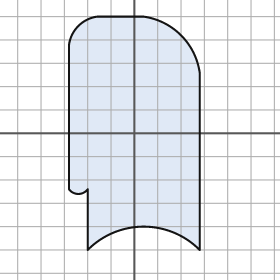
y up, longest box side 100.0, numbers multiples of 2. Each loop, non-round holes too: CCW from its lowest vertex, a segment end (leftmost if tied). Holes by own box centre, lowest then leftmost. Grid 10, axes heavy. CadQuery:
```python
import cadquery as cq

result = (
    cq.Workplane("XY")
    .moveTo(-20.0, -50.0)
    .threePointArc((4.0, -40.0), (28.0, -50.0))
    .lineTo(28.0, 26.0)
    .threePointArc((20.0, 42.0), (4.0, 50.0))
    .lineTo(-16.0, 50.0)
    .threePointArc((-24.0, 46.0), (-28.0, 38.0))
    .lineTo(-28.0, -24.0)
    .threePointArc((-24.0, -26.0), (-20.0, -24.0))
    .close()
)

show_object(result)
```